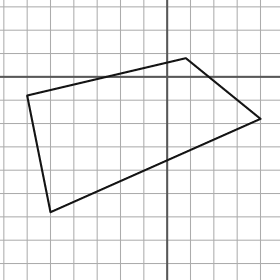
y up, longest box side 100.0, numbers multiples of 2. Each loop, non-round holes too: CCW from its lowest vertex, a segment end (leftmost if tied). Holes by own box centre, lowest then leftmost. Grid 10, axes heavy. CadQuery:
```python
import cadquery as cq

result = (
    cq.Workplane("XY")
    .moveTo(-50.0, -58.0)
    .lineTo(40.0, -18.0)
    .lineTo(8.0, 8.0)
    .lineTo(-60.0, -8.0)
    .close()
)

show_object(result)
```